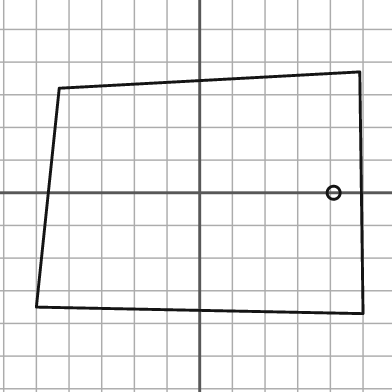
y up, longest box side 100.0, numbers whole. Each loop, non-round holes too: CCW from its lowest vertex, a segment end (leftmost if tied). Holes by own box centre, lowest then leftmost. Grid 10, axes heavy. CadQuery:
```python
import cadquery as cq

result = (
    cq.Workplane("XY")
    .moveTo(50.0, -37.0)
    .lineTo(49.0, 37.0)
    .lineTo(-43.0, 32.0)
    .lineTo(-50.0, -35.0)
    .close()
    .moveTo(41.0, 0.0)
    .circle(2.0)
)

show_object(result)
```